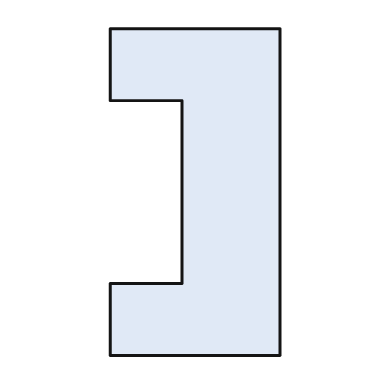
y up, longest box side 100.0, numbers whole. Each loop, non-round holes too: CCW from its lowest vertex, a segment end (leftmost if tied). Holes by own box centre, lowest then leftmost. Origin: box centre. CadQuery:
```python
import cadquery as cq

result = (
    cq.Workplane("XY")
    .moveTo(-26.0, -50.0)
    .lineTo(26.0, -50.0)
    .lineTo(26.0, 50.0)
    .lineTo(-26.0, 50.0)
    .lineTo(-26.0, 28.0)
    .lineTo(-4.0, 28.0)
    .lineTo(-4.0, -28.0)
    .lineTo(-26.0, -28.0)
    .close()
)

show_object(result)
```